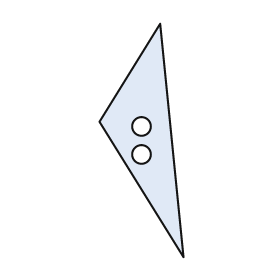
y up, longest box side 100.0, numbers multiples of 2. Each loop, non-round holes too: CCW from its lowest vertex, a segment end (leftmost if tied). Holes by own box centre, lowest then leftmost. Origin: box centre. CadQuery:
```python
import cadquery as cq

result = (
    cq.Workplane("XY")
    .moveTo(18.0, -50.0)
    .lineTo(8.0, 50.0)
    .lineTo(-18.0, 8.0)
    .close()
    .moveTo(0.0, -6.0)
    .circle(4.0)
    .moveTo(0.0, 6.0)
    .circle(4.0)
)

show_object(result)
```